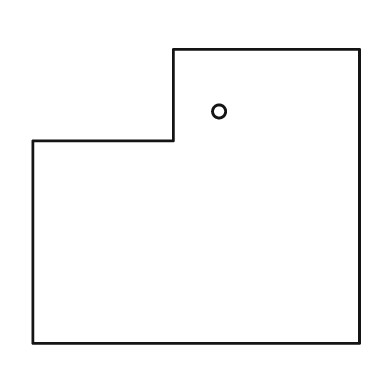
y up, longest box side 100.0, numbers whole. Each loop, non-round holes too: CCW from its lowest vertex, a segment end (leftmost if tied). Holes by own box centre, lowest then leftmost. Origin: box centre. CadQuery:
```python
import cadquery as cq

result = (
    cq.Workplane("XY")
    .moveTo(-50.0, -45.0)
    .lineTo(50.0, -45.0)
    .lineTo(50.0, 45.0)
    .lineTo(-7.0, 45.0)
    .lineTo(-7.0, 17.0)
    .lineTo(-50.0, 17.0)
    .close()
    .moveTo(7.0, 26.0)
    .circle(2.0)
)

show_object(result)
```